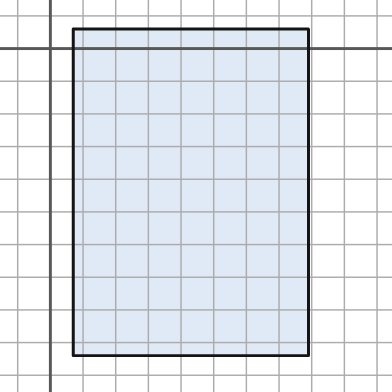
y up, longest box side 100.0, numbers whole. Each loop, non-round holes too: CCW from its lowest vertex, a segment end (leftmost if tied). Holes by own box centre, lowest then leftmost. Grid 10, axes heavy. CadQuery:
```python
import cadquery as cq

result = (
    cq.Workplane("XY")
    .moveTo(7.0, -94.0)
    .lineTo(79.0, -94.0)
    .lineTo(79.0, 6.0)
    .lineTo(7.0, 6.0)
    .close()
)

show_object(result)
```